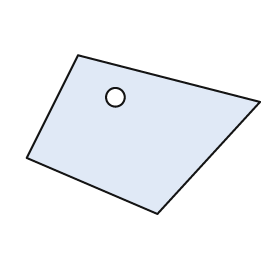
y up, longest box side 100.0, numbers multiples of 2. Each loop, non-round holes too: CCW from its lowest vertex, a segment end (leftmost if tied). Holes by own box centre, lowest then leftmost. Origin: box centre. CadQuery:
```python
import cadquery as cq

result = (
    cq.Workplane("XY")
    .moveTo(6.0, -34.0)
    .lineTo(50.0, 14.0)
    .lineTo(-28.0, 34.0)
    .lineTo(-50.0, -10.0)
    .close()
    .moveTo(-12.0, 16.0)
    .circle(4.0)
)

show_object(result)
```